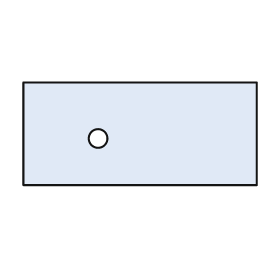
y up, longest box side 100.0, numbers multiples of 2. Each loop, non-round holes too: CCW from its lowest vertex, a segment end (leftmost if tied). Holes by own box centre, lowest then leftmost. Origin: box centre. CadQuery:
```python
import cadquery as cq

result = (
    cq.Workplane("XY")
    .moveTo(-50.0, -22.0)
    .lineTo(50.0, -22.0)
    .lineTo(50.0, 22.0)
    .lineTo(-50.0, 22.0)
    .close()
    .moveTo(-18.0, -2.0)
    .circle(4.0)
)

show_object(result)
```